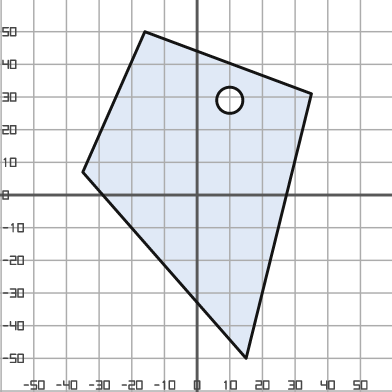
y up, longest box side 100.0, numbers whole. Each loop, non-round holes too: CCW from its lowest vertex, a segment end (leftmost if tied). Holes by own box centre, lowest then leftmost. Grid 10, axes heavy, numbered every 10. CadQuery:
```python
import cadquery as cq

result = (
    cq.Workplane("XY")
    .moveTo(15.0, -50.0)
    .lineTo(35.0, 31.0)
    .lineTo(-16.0, 50.0)
    .lineTo(-35.0, 7.0)
    .close()
    .moveTo(10.0, 29.0)
    .circle(4.0)
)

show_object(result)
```